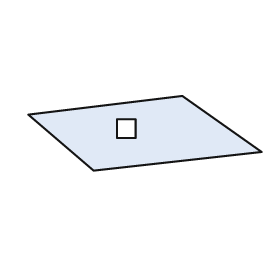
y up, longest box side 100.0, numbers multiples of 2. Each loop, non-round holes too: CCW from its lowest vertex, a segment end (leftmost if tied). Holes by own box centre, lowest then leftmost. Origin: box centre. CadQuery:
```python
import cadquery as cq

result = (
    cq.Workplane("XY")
    .moveTo(-22.0, -16.0)
    .lineTo(50.0, -8.0)
    .lineTo(16.0, 16.0)
    .lineTo(-50.0, 8.0)
    .close()
    .moveTo(-12.0, -2.0)
    .lineTo(-4.0, -2.0)
    .lineTo(-4.0, 6.0)
    .lineTo(-12.0, 6.0)
    .close()
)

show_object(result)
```